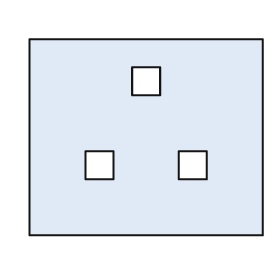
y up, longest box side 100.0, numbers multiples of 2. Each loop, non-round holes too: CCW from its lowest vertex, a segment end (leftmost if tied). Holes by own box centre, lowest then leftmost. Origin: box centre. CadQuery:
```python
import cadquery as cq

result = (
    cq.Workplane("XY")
    .moveTo(-50.0, -42.0)
    .lineTo(50.0, -42.0)
    .lineTo(50.0, 42.0)
    .lineTo(-50.0, 42.0)
    .close()
    .moveTo(-26.0, -18.0)
    .lineTo(-14.0, -18.0)
    .lineTo(-14.0, -6.0)
    .lineTo(-26.0, -6.0)
    .close()
    .moveTo(14.0, -18.0)
    .lineTo(26.0, -18.0)
    .lineTo(26.0, -6.0)
    .lineTo(14.0, -6.0)
    .close()
    .moveTo(-6.0, 18.0)
    .lineTo(6.0, 18.0)
    .lineTo(6.0, 30.0)
    .lineTo(-6.0, 30.0)
    .close()
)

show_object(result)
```